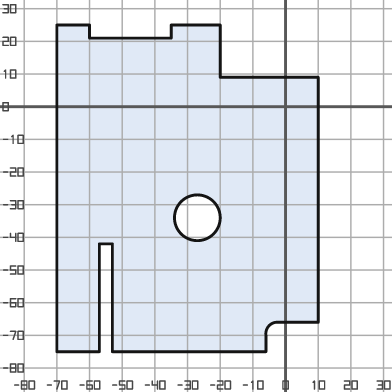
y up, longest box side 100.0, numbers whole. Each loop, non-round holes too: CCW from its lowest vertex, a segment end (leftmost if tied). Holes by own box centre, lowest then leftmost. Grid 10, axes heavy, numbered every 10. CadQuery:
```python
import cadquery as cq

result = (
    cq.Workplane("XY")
    .moveTo(-70.0, -75.0)
    .lineTo(-57.0, -75.0)
    .lineTo(-57.0, -42.0)
    .lineTo(-53.0, -42.0)
    .lineTo(-53.0, -75.0)
    .lineTo(-6.0, -75.0)
    .lineTo(-6.0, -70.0)
    .threePointArc((-5.0, -67.0), (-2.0, -66.0))
    .lineTo(10.0, -66.0)
    .lineTo(10.0, 9.0)
    .lineTo(-20.0, 9.0)
    .lineTo(-20.0, 25.0)
    .lineTo(-35.0, 25.0)
    .lineTo(-35.0, 21.0)
    .lineTo(-60.0, 21.0)
    .lineTo(-60.0, 25.0)
    .lineTo(-70.0, 25.0)
    .close()
    .moveTo(-27.0, -34.0)
    .circle(7.0)
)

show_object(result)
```